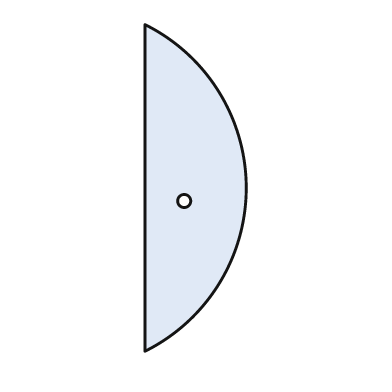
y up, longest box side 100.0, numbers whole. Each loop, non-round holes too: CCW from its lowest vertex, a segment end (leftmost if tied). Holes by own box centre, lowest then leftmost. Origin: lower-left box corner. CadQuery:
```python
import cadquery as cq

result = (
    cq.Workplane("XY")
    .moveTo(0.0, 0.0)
    .threePointArc((31.0, 50.0), (0.0, 100.0))
    .close()
    .moveTo(12.0, 46.0)
    .circle(2.0)
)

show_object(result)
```